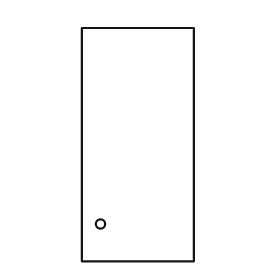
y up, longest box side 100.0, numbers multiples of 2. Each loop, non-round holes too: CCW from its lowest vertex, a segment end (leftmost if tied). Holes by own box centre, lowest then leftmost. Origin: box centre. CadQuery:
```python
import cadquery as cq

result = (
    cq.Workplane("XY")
    .moveTo(-24.0, -50.0)
    .lineTo(24.0, -50.0)
    .lineTo(24.0, 50.0)
    .lineTo(-24.0, 50.0)
    .close()
    .moveTo(-16.0, -34.0)
    .circle(2.0)
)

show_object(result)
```